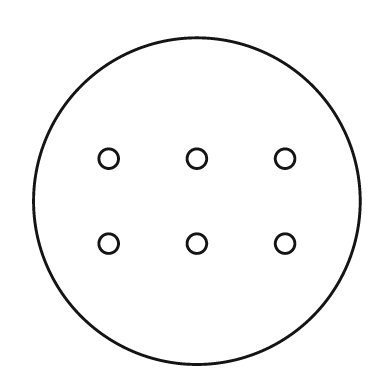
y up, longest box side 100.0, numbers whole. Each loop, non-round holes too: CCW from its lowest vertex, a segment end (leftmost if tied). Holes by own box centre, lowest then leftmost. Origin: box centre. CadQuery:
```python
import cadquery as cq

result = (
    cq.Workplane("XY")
    .moveTo(0.0, 0.0)
    .circle(50.0)
    .moveTo(-27.0, -13.0)
    .circle(3.0)
    .moveTo(0.0, -13.0)
    .circle(3.0)
    .moveTo(27.0, -13.0)
    .circle(3.0)
    .moveTo(-27.0, 13.0)
    .circle(3.0)
    .moveTo(0.0, 13.0)
    .circle(3.0)
    .moveTo(27.0, 13.0)
    .circle(3.0)
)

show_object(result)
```